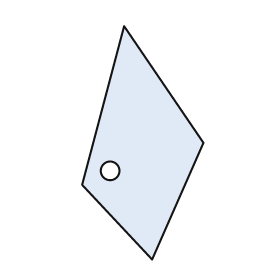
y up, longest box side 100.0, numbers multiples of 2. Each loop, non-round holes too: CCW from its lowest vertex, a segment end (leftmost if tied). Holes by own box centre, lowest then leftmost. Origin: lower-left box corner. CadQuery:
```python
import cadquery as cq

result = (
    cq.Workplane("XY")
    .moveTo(30.0, 0.0)
    .lineTo(52.0, 50.0)
    .lineTo(18.0, 100.0)
    .lineTo(0.0, 32.0)
    .close()
    .moveTo(12.0, 38.0)
    .circle(4.0)
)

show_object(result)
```